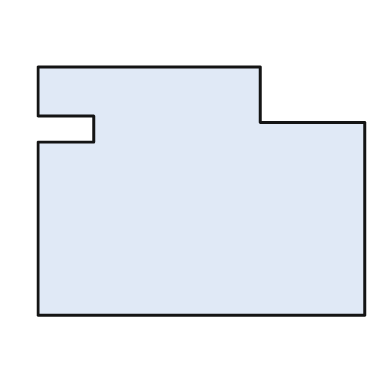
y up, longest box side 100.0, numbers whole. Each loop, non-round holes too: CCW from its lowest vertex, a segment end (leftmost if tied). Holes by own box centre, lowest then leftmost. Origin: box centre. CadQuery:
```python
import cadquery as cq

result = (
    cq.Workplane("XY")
    .moveTo(-50.0, -38.0)
    .lineTo(50.0, -38.0)
    .lineTo(50.0, 21.0)
    .lineTo(18.0, 21.0)
    .lineTo(18.0, 38.0)
    .lineTo(-50.0, 38.0)
    .lineTo(-50.0, 23.0)
    .lineTo(-33.0, 23.0)
    .lineTo(-33.0, 15.0)
    .lineTo(-50.0, 15.0)
    .close()
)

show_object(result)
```